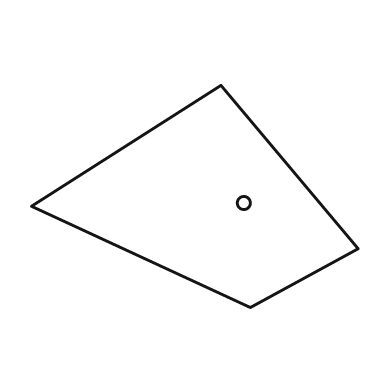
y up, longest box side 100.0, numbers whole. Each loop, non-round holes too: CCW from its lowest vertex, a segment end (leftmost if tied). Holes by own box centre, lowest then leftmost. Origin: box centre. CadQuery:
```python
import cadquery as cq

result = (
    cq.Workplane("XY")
    .moveTo(17.0, -34.0)
    .lineTo(50.0, -16.0)
    .lineTo(8.0, 34.0)
    .lineTo(-50.0, -3.0)
    .close()
    .moveTo(15.0, -2.0)
    .circle(2.0)
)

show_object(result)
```